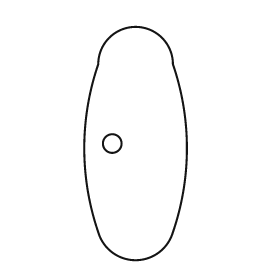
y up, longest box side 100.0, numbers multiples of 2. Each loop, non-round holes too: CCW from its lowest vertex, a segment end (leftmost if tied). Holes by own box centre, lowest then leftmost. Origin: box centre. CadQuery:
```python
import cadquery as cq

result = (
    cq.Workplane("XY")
    .moveTo(-16.0, -38.0)
    .threePointArc((0.0, -50.0), (16.0, -38.0))
    .threePointArc((22.0, -2.0), (16.0, 34.0))
    .threePointArc((0.0, 50.0), (-16.0, 34.0))
    .threePointArc((-22.0, -2.0), (-16.0, -38.0))
    .close()
    .moveTo(-10.0, 0.0)
    .circle(4.0)
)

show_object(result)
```